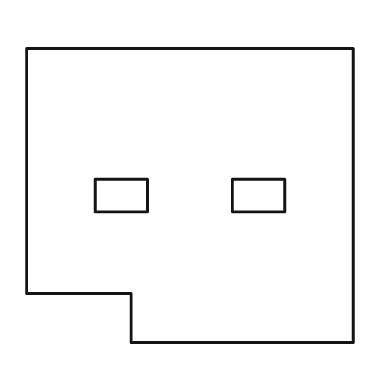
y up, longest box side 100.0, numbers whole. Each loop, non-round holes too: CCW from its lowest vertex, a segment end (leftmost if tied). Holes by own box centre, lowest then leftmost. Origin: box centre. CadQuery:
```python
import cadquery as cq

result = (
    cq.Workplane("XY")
    .moveTo(-18.0, -45.0)
    .lineTo(50.0, -45.0)
    .lineTo(50.0, 45.0)
    .lineTo(-50.0, 45.0)
    .lineTo(-50.0, -30.0)
    .lineTo(-18.0, -30.0)
    .close()
    .moveTo(-29.0, -5.0)
    .lineTo(-13.0, -5.0)
    .lineTo(-13.0, 5.0)
    .lineTo(-29.0, 5.0)
    .close()
    .moveTo(13.0, -5.0)
    .lineTo(29.0, -5.0)
    .lineTo(29.0, 5.0)
    .lineTo(13.0, 5.0)
    .close()
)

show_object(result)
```